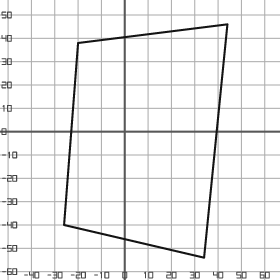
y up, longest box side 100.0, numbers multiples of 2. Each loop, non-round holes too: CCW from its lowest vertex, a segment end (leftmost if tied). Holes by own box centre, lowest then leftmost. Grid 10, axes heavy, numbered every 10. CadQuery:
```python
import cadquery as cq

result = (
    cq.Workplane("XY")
    .moveTo(34.0, -54.0)
    .lineTo(44.0, 46.0)
    .lineTo(-20.0, 38.0)
    .lineTo(-26.0, -40.0)
    .close()
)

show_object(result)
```